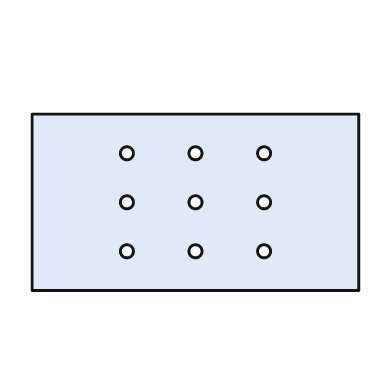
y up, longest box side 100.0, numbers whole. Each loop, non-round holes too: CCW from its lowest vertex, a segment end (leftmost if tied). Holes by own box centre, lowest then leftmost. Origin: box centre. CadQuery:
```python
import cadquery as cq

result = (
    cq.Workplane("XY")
    .moveTo(-50.0, -27.0)
    .lineTo(50.0, -27.0)
    .lineTo(50.0, 27.0)
    .lineTo(-50.0, 27.0)
    .close()
    .moveTo(-21.0, -15.0)
    .circle(2.0)
    .moveTo(0.0, -15.0)
    .circle(2.0)
    .moveTo(21.0, -15.0)
    .circle(2.0)
    .moveTo(-21.0, 0.0)
    .circle(2.0)
    .moveTo(0.0, 0.0)
    .circle(2.0)
    .moveTo(21.0, 0.0)
    .circle(2.0)
    .moveTo(-21.0, 15.0)
    .circle(2.0)
    .moveTo(0.0, 15.0)
    .circle(2.0)
    .moveTo(21.0, 15.0)
    .circle(2.0)
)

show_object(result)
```